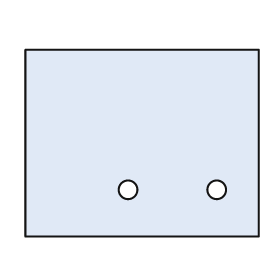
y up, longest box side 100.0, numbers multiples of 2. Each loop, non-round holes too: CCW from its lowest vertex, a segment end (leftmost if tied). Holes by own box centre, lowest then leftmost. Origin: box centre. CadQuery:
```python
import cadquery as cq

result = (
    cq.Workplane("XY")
    .moveTo(-50.0, -40.0)
    .lineTo(50.0, -40.0)
    .lineTo(50.0, 40.0)
    .lineTo(-50.0, 40.0)
    .close()
    .moveTo(-6.0, -20.0)
    .circle(4.0)
    .moveTo(32.0, -20.0)
    .circle(4.0)
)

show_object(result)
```